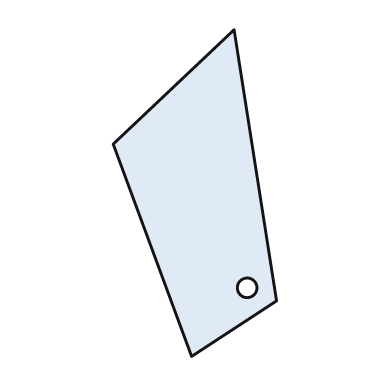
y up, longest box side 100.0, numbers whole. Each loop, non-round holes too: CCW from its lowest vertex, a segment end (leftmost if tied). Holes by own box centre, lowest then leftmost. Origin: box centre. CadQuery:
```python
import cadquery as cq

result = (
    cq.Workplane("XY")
    .moveTo(-1.0, -50.0)
    .lineTo(25.0, -33.0)
    .lineTo(12.0, 50.0)
    .lineTo(-25.0, 15.0)
    .close()
    .moveTo(16.0, -29.0)
    .circle(3.0)
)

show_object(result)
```